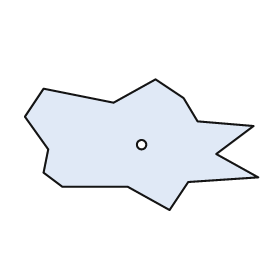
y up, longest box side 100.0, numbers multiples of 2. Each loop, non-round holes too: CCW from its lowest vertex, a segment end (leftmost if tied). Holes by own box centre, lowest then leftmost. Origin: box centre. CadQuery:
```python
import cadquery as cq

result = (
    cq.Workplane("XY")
    .moveTo(12.0, -28.0)
    .lineTo(20.0, -16.0)
    .lineTo(50.0, -14.0)
    .lineTo(32.0, -4.0)
    .lineTo(48.0, 8.0)
    .lineTo(24.0, 10.0)
    .lineTo(18.0, 20.0)
    .lineTo(6.0, 28.0)
    .lineTo(-12.0, 18.0)
    .lineTo(-42.0, 24.0)
    .lineTo(-50.0, 12.0)
    .lineTo(-40.0, -2.0)
    .lineTo(-42.0, -12.0)
    .lineTo(-34.0, -18.0)
    .lineTo(-6.0, -18.0)
    .close()
    .moveTo(0.0, 0.0)
    .circle(2.0)
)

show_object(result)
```